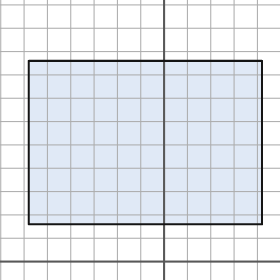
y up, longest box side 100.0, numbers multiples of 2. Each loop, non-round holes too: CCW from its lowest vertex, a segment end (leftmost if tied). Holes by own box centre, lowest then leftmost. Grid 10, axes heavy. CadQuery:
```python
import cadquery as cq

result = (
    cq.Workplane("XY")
    .moveTo(-58.0, 16.0)
    .lineTo(42.0, 16.0)
    .lineTo(42.0, 86.0)
    .lineTo(-58.0, 86.0)
    .close()
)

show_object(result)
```